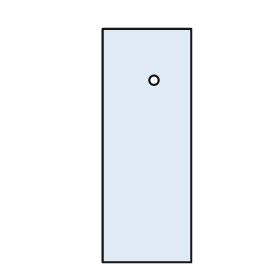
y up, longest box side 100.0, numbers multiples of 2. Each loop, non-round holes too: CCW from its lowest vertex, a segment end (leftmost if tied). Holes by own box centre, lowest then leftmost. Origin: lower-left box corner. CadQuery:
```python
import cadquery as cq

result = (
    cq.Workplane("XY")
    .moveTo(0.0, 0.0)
    .lineTo(38.0, 0.0)
    .lineTo(38.0, 100.0)
    .lineTo(0.0, 100.0)
    .close()
    .moveTo(22.0, 78.0)
    .circle(2.0)
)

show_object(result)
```